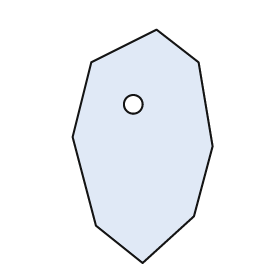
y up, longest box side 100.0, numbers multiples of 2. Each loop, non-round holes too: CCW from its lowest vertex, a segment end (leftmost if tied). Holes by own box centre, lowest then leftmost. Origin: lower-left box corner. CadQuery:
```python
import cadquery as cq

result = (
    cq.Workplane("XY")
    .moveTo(30.0, 0.0)
    .lineTo(52.0, 20.0)
    .lineTo(60.0, 50.0)
    .lineTo(54.0, 86.0)
    .lineTo(36.0, 100.0)
    .lineTo(8.0, 86.0)
    .lineTo(0.0, 54.0)
    .lineTo(10.0, 16.0)
    .close()
    .moveTo(26.0, 68.0)
    .circle(4.0)
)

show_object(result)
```